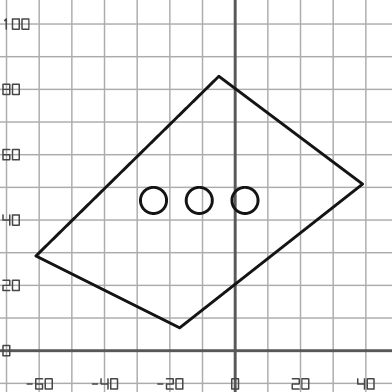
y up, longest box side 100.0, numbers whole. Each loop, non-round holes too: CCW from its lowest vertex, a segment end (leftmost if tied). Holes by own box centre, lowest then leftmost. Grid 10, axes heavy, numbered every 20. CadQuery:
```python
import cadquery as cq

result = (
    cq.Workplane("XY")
    .moveTo(-17.0, 7.0)
    .lineTo(39.0, 51.0)
    .lineTo(-5.0, 84.0)
    .lineTo(-61.0, 29.0)
    .close()
    .moveTo(-25.0, 46.0)
    .circle(4.0)
    .moveTo(-11.0, 46.0)
    .circle(4.0)
    .moveTo(3.0, 46.0)
    .circle(4.0)
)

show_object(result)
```